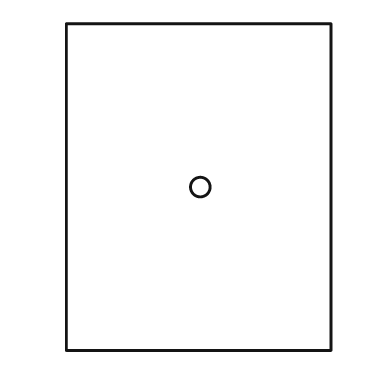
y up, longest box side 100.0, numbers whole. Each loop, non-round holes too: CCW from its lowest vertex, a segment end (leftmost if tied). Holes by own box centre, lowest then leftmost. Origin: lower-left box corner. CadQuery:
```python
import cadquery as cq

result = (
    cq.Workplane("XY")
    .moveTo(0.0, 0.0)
    .lineTo(81.0, 0.0)
    .lineTo(81.0, 100.0)
    .lineTo(0.0, 100.0)
    .close()
    .moveTo(41.0, 50.0)
    .circle(3.0)
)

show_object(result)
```